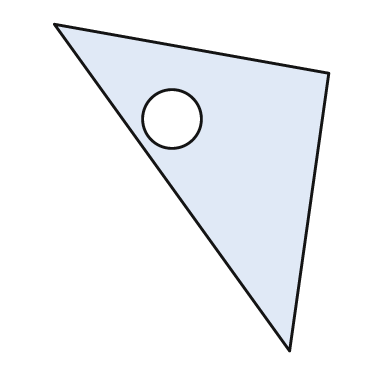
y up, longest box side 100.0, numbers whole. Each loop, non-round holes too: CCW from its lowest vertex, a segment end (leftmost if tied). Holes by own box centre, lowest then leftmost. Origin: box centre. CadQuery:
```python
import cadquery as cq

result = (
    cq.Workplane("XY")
    .moveTo(30.0, -50.0)
    .lineTo(42.0, 35.0)
    .lineTo(-42.0, 50.0)
    .close()
    .moveTo(-6.0, 21.0)
    .circle(9.0)
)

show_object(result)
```